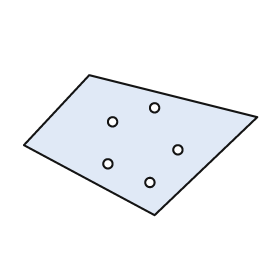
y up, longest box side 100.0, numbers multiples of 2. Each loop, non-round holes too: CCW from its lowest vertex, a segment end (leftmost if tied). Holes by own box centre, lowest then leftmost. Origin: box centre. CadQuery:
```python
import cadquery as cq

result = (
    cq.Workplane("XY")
    .moveTo(6.0, -30.0)
    .lineTo(50.0, 12.0)
    .lineTo(-22.0, 30.0)
    .lineTo(-50.0, 0.0)
    .close()
    .moveTo(4.0, -16.0)
    .circle(2.0)
    .moveTo(-14.0, -8.0)
    .circle(2.0)
    .moveTo(16.0, -2.0)
    .circle(2.0)
    .moveTo(-12.0, 10.0)
    .circle(2.0)
    .moveTo(6.0, 16.0)
    .circle(2.0)
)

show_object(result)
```